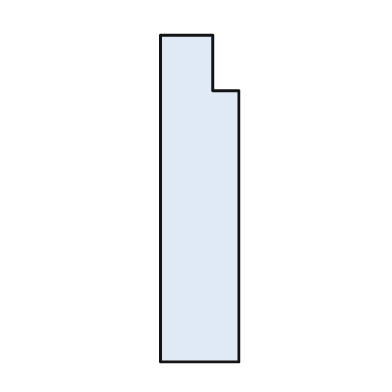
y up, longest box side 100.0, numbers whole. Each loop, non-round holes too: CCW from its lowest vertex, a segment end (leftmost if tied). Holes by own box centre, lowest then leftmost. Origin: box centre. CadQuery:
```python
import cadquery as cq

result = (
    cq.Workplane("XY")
    .moveTo(-12.0, -50.0)
    .lineTo(12.0, -50.0)
    .lineTo(12.0, 33.0)
    .lineTo(4.0, 33.0)
    .lineTo(4.0, 50.0)
    .lineTo(-12.0, 50.0)
    .close()
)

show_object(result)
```